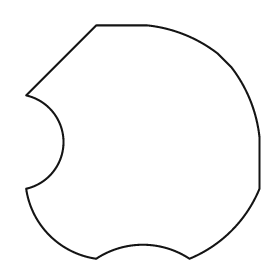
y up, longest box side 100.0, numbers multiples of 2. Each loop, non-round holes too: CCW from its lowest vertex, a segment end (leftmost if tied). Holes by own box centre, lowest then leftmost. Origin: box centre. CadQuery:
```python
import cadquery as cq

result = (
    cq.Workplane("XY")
    .moveTo(-20.0, -50.0)
    .threePointArc((0.0, -44.0), (20.0, -50.0))
    .threePointArc((38.0, -38.0), (50.0, -20.0))
    .lineTo(50.0, 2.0)
    .threePointArc((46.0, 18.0), (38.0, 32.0))
    .lineTo(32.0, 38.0)
    .threePointArc((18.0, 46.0), (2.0, 50.0))
    .lineTo(-20.0, 50.0)
    .lineTo(-50.0, 20.0)
    .threePointArc((-34.0, 0.0), (-50.0, -20.0))
    .threePointArc((-40.0, -40.0), (-20.0, -50.0))
    .close()
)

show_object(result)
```